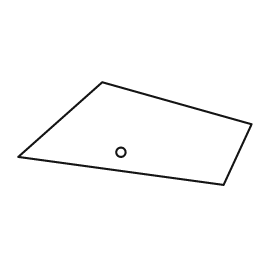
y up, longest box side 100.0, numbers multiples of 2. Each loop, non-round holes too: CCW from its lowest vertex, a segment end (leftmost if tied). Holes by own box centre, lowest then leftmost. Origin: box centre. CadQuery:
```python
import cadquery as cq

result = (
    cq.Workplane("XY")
    .moveTo(38.0, -22.0)
    .lineTo(50.0, 4.0)
    .lineTo(-14.0, 22.0)
    .lineTo(-50.0, -10.0)
    .close()
    .moveTo(-6.0, -8.0)
    .circle(2.0)
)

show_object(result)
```